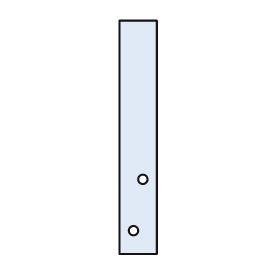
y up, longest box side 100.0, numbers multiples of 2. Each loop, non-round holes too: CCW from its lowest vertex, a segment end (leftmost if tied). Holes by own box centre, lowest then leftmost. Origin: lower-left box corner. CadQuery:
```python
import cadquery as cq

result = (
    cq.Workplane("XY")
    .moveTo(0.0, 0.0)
    .lineTo(16.0, 0.0)
    .lineTo(16.0, 100.0)
    .lineTo(0.0, 100.0)
    .close()
    .moveTo(6.0, 10.0)
    .circle(2.0)
    .moveTo(10.0, 32.0)
    .circle(2.0)
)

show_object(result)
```